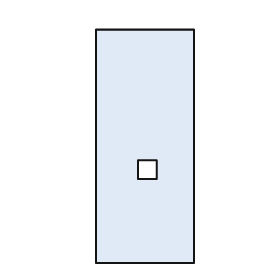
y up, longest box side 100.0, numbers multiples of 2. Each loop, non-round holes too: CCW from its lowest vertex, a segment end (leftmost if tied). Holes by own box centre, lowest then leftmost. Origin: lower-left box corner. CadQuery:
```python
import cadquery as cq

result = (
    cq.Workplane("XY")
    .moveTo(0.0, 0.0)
    .lineTo(42.0, 0.0)
    .lineTo(42.0, 100.0)
    .lineTo(0.0, 100.0)
    .close()
    .moveTo(18.0, 36.0)
    .lineTo(26.0, 36.0)
    .lineTo(26.0, 44.0)
    .lineTo(18.0, 44.0)
    .close()
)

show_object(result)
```